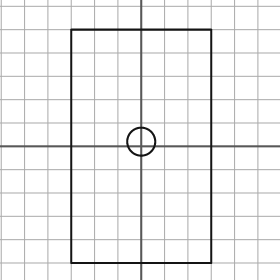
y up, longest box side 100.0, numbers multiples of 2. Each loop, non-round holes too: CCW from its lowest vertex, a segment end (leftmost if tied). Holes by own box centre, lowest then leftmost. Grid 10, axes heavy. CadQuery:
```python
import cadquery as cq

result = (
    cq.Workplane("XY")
    .moveTo(-30.0, -50.0)
    .lineTo(30.0, -50.0)
    .lineTo(30.0, 50.0)
    .lineTo(-30.0, 50.0)
    .close()
    .moveTo(0.0, 2.0)
    .circle(6.0)
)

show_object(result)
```